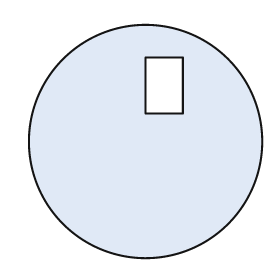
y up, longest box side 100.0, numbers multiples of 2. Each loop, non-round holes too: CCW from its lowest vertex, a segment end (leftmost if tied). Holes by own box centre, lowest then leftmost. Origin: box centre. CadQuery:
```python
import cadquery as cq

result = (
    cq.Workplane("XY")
    .moveTo(0.0, 0.0)
    .circle(50.0)
    .moveTo(0.0, 12.0)
    .lineTo(16.0, 12.0)
    .lineTo(16.0, 36.0)
    .lineTo(0.0, 36.0)
    .close()
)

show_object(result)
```